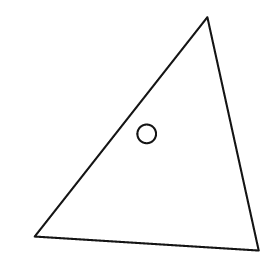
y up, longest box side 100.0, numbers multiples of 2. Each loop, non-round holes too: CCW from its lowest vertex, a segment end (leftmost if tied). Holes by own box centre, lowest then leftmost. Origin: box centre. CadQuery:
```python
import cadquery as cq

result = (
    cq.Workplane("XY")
    .moveTo(48.0, -50.0)
    .lineTo(26.0, 50.0)
    .lineTo(-48.0, -44.0)
    .close()
    .moveTo(0.0, 0.0)
    .circle(4.0)
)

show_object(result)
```